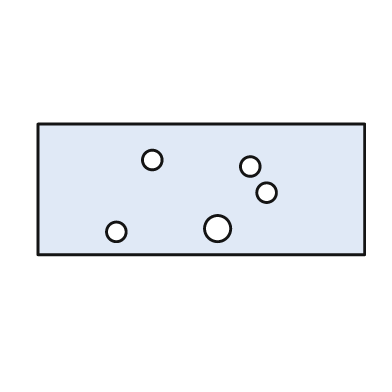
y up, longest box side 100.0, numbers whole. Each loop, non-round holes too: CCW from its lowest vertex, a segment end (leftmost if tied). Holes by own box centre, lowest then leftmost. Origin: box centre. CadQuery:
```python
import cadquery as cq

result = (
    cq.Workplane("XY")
    .moveTo(-50.0, -20.0)
    .lineTo(50.0, -20.0)
    .lineTo(50.0, 20.0)
    .lineTo(-50.0, 20.0)
    .close()
    .moveTo(-26.0, -13.0)
    .circle(3.0)
    .moveTo(5.0, -12.0)
    .circle(4.0)
    .moveTo(20.0, -1.0)
    .circle(3.0)
    .moveTo(15.0, 7.0)
    .circle(3.0)
    .moveTo(-15.0, 9.0)
    .circle(3.0)
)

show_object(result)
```